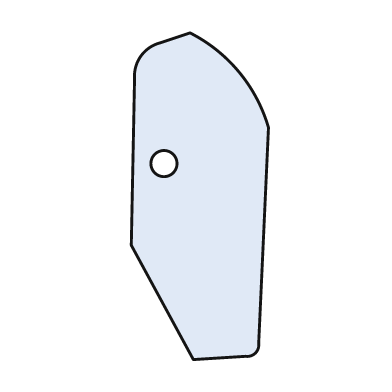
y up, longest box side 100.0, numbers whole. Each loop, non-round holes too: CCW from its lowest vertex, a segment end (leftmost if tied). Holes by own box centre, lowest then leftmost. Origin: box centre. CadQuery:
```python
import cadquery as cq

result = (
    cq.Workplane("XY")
    .moveTo(-2.0, -50.0)
    .lineTo(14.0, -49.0)
    .threePointArc((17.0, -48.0), (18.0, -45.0))
    .lineTo(21.0, 21.0)
    .threePointArc((12.0, 38.0), (-3.0, 50.0))
    .lineTo(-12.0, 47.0)
    .threePointArc((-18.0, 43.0), (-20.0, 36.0))
    .lineTo(-21.0, -15.0)
    .close()
    .moveTo(-11.0, 10.0)
    .circle(4.0)
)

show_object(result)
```